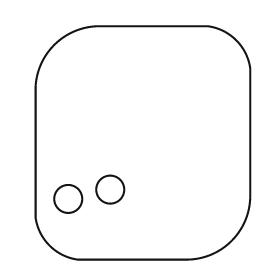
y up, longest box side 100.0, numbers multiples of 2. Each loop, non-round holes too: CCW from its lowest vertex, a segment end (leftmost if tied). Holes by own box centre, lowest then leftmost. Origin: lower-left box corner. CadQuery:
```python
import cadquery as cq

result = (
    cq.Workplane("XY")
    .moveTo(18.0, 0.0)
    .lineTo(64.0, 0.0)
    .threePointArc((84.0, 8.0), (92.0, 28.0))
    .lineTo(92.0, 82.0)
    .threePointArc((86.0, 94.0), (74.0, 100.0))
    .lineTo(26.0, 100.0)
    .threePointArc((8.0, 92.0), (0.0, 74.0))
    .lineTo(0.0, 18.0)
    .threePointArc((6.0, 6.0), (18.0, 0.0))
    .close()
    .moveTo(14.0, 26.0)
    .circle(6.0)
    .moveTo(32.0, 30.0)
    .circle(6.0)
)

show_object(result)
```